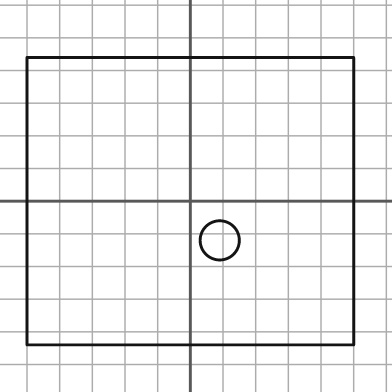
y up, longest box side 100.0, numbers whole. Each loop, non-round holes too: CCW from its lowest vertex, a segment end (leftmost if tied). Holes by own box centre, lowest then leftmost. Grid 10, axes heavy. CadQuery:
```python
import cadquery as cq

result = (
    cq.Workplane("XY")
    .moveTo(-50.0, -44.0)
    .lineTo(50.0, -44.0)
    .lineTo(50.0, 44.0)
    .lineTo(-50.0, 44.0)
    .close()
    .moveTo(9.0, -12.0)
    .circle(6.0)
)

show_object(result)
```